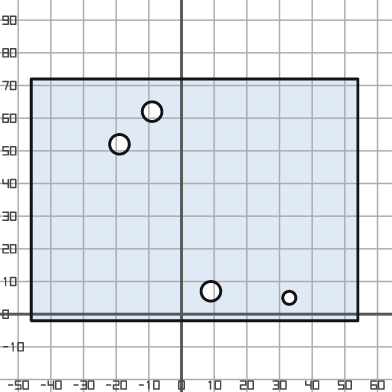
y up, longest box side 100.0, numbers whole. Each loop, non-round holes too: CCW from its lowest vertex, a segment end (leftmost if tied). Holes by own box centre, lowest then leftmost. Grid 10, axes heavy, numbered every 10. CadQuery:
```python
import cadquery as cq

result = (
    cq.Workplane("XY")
    .moveTo(-46.0, -2.0)
    .lineTo(54.0, -2.0)
    .lineTo(54.0, 72.0)
    .lineTo(-46.0, 72.0)
    .close()
    .moveTo(33.0, 5.0)
    .circle(2.0)
    .moveTo(9.0, 7.0)
    .circle(3.0)
    .moveTo(-19.0, 52.0)
    .circle(3.0)
    .moveTo(-9.0, 62.0)
    .circle(3.0)
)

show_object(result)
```